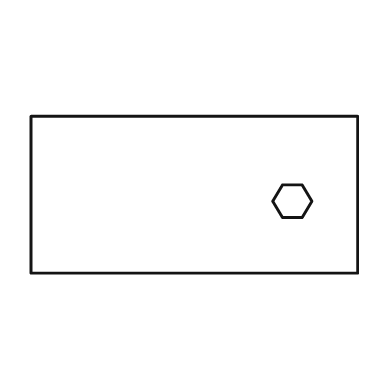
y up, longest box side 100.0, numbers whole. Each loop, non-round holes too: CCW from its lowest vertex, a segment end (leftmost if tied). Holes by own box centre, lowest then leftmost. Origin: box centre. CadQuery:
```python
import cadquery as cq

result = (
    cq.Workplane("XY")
    .moveTo(-50.0, -24.0)
    .lineTo(50.0, -24.0)
    .lineTo(50.0, 24.0)
    .lineTo(-50.0, 24.0)
    .close()
    .moveTo(27.0, -7.0)
    .lineTo(33.0, -7.0)
    .lineTo(36.0, -2.0)
    .lineTo(33.0, 3.0)
    .lineTo(27.0, 3.0)
    .lineTo(24.0, -2.0)
    .close()
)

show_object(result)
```